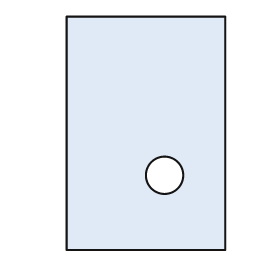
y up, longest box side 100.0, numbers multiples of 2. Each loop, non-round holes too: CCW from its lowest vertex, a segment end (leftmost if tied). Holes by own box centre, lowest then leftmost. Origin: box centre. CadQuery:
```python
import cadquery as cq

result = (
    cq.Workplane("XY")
    .moveTo(-34.0, -50.0)
    .lineTo(34.0, -50.0)
    .lineTo(34.0, 50.0)
    .lineTo(-34.0, 50.0)
    .close()
    .moveTo(8.0, -18.0)
    .circle(8.0)
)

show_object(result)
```